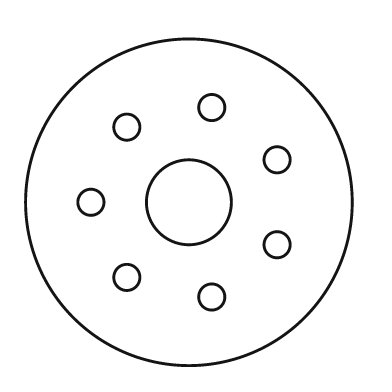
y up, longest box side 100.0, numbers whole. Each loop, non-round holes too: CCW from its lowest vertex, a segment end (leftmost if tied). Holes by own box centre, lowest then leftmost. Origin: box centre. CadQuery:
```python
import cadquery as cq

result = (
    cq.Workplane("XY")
    .moveTo(0.0, 0.0)
    .circle(50.0)
    .moveTo(7.0, -29.0)
    .circle(4.0)
    .moveTo(-19.0, -23.0)
    .circle(4.0)
    .moveTo(27.0, -13.0)
    .circle(4.0)
    .moveTo(-30.0, 0.0)
    .circle(4.0)
    .moveTo(0.0, 0.0)
    .circle(13.0)
    .moveTo(27.0, 13.0)
    .circle(4.0)
    .moveTo(-19.0, 23.0)
    .circle(4.0)
    .moveTo(7.0, 29.0)
    .circle(4.0)
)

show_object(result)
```